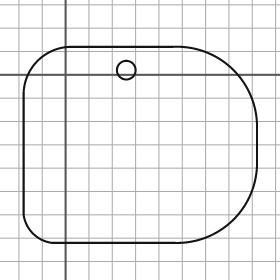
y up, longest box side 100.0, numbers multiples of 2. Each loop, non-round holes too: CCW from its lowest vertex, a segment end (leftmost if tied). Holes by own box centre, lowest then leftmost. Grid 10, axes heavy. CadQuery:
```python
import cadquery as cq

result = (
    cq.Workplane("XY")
    .moveTo(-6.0, -72.0)
    .lineTo(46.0, -72.0)
    .threePointArc((72.0, -62.0), (82.0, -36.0))
    .lineTo(82.0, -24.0)
    .threePointArc((72.0, 2.0), (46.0, 12.0))
    .lineTo(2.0, 12.0)
    .threePointArc((-12.0, 6.0), (-18.0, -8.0))
    .lineTo(-18.0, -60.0)
    .threePointArc((-14.0, -68.0), (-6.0, -72.0))
    .close()
    .moveTo(26.0, 2.0)
    .circle(4.0)
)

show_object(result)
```